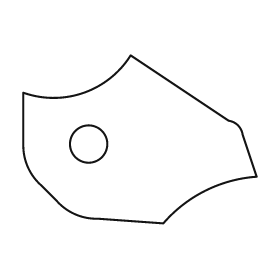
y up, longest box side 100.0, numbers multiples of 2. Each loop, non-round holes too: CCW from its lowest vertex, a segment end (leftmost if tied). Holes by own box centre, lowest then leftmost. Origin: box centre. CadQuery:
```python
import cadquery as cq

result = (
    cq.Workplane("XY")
    .moveTo(10.0, -36.0)
    .threePointArc((28.0, -22.0), (50.0, -16.0))
    .lineTo(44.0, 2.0)
    .threePointArc((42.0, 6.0), (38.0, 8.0))
    .lineTo(-4.0, 36.0)
    .threePointArc((-24.0, 20.0), (-50.0, 20.0))
    .lineTo(-50.0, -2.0)
    .threePointArc((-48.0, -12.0), (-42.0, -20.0))
    .lineTo(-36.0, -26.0)
    .threePointArc((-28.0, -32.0), (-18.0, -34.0))
    .close()
    .moveTo(-22.0, -2.0)
    .circle(8.0)
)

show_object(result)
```